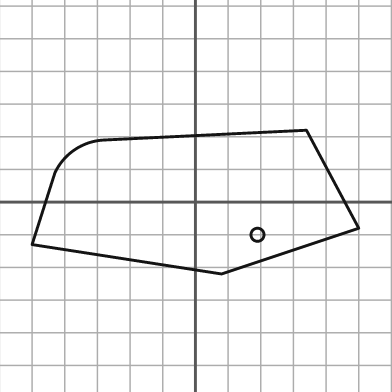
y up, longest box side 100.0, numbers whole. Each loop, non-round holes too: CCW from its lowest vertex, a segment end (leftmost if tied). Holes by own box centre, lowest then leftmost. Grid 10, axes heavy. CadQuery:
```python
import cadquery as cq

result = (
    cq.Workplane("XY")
    .moveTo(8.0, -22.0)
    .lineTo(50.0, -8.0)
    .lineTo(34.0, 22.0)
    .lineTo(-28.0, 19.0)
    .threePointArc((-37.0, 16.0), (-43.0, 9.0))
    .lineTo(-50.0, -13.0)
    .close()
    .moveTo(19.0, -10.0)
    .circle(2.0)
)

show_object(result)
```